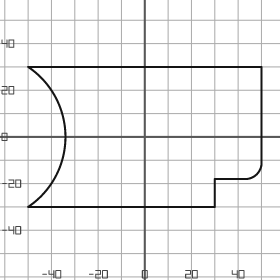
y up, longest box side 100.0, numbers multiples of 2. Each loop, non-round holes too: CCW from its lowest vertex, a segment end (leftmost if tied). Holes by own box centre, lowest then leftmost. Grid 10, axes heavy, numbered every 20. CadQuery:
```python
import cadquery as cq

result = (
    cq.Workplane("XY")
    .moveTo(-50.0, -30.0)
    .lineTo(30.0, -30.0)
    .lineTo(30.0, -18.0)
    .lineTo(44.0, -18.0)
    .threePointArc((48.0, -16.0), (50.0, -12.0))
    .lineTo(50.0, 30.0)
    .lineTo(-50.0, 30.0)
    .threePointArc((-34.0, 0.0), (-50.0, -30.0))
    .close()
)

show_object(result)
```